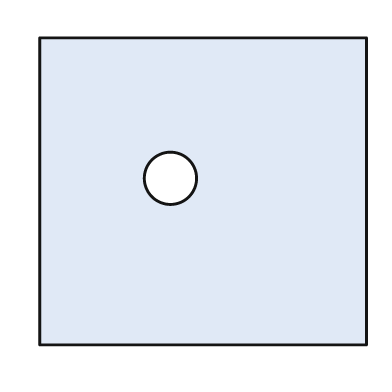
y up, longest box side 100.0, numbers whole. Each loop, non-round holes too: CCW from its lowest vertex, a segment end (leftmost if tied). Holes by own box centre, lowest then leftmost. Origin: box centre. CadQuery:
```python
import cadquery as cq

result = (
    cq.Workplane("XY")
    .moveTo(-50.0, -47.0)
    .lineTo(50.0, -47.0)
    .lineTo(50.0, 47.0)
    .lineTo(-50.0, 47.0)
    .close()
    .moveTo(-10.0, 4.0)
    .circle(8.0)
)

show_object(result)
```